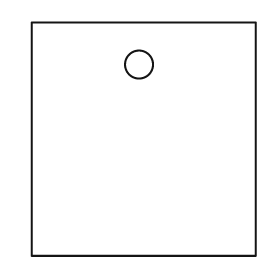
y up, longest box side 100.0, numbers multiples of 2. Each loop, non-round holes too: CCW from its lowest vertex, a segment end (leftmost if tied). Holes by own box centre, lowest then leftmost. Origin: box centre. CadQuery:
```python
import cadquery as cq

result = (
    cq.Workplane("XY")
    .moveTo(-48.0, -50.0)
    .lineTo(48.0, -50.0)
    .lineTo(48.0, 50.0)
    .lineTo(-48.0, 50.0)
    .close()
    .moveTo(-2.0, 32.0)
    .circle(6.0)
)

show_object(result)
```